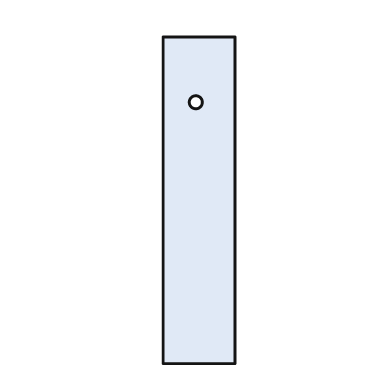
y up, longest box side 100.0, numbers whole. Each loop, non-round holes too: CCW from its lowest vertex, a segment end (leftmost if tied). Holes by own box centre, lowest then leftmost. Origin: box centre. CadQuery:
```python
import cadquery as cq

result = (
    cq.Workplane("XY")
    .moveTo(-11.0, -50.0)
    .lineTo(11.0, -50.0)
    .lineTo(11.0, 50.0)
    .lineTo(-11.0, 50.0)
    .close()
    .moveTo(-1.0, 30.0)
    .circle(2.0)
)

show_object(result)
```